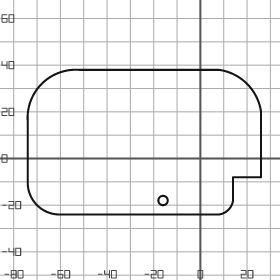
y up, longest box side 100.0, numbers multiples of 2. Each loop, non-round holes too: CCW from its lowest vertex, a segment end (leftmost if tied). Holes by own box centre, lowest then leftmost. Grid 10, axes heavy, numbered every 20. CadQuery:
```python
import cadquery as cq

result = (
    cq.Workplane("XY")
    .moveTo(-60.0, -24.0)
    .lineTo(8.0, -24.0)
    .threePointArc((12.0, -22.0), (14.0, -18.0))
    .lineTo(14.0, -8.0)
    .lineTo(26.0, -8.0)
    .lineTo(26.0, 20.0)
    .threePointArc((20.0, 32.0), (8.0, 38.0))
    .lineTo(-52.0, 38.0)
    .threePointArc((-68.0, 32.0), (-74.0, 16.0))
    .lineTo(-74.0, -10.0)
    .threePointArc((-70.0, -20.0), (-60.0, -24.0))
    .close()
    .moveTo(-16.0, -18.0)
    .circle(2.0)
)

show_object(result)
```